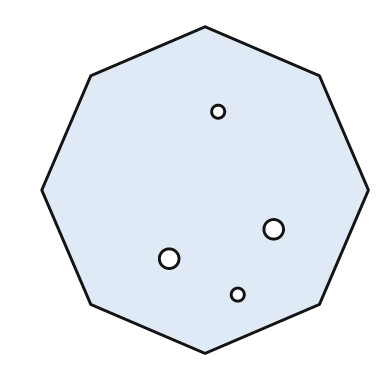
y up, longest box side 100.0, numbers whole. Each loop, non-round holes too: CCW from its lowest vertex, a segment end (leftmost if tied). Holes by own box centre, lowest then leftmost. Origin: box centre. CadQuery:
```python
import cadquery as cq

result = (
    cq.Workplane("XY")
    .moveTo(0.0, -50.0)
    .lineTo(35.0, -35.0)
    .lineTo(50.0, 0.0)
    .lineTo(35.0, 35.0)
    .lineTo(0.0, 50.0)
    .lineTo(-35.0, 35.0)
    .lineTo(-50.0, 0.0)
    .lineTo(-35.0, -35.0)
    .close()
    .moveTo(10.0, -32.0)
    .circle(2.0)
    .moveTo(-11.0, -21.0)
    .circle(3.0)
    .moveTo(21.0, -12.0)
    .circle(3.0)
    .moveTo(4.0, 24.0)
    .circle(2.0)
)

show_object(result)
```